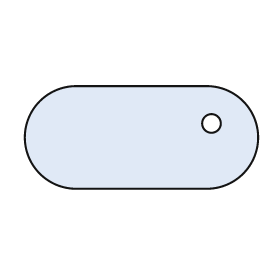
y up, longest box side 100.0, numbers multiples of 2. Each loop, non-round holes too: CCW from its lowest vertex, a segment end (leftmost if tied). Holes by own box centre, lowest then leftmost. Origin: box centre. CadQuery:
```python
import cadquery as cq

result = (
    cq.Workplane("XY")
    .moveTo(-28.0, -22.0)
    .lineTo(28.0, -22.0)
    .threePointArc((50.0, 0.0), (28.0, 22.0))
    .lineTo(-28.0, 22.0)
    .threePointArc((-50.0, 0.0), (-28.0, -22.0))
    .close()
    .moveTo(30.0, 6.0)
    .circle(4.0)
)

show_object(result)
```